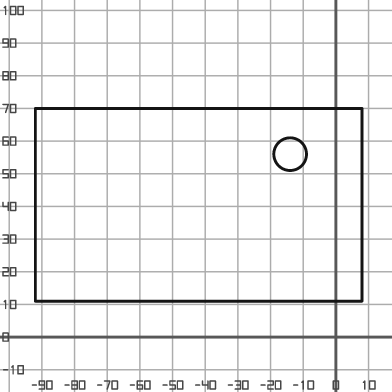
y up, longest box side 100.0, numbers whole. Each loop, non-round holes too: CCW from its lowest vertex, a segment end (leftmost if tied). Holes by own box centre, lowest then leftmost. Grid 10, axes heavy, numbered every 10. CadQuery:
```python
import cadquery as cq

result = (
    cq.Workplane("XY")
    .moveTo(-92.0, 11.0)
    .lineTo(8.0, 11.0)
    .lineTo(8.0, 70.0)
    .lineTo(-92.0, 70.0)
    .close()
    .moveTo(-14.0, 56.0)
    .circle(5.0)
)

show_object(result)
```